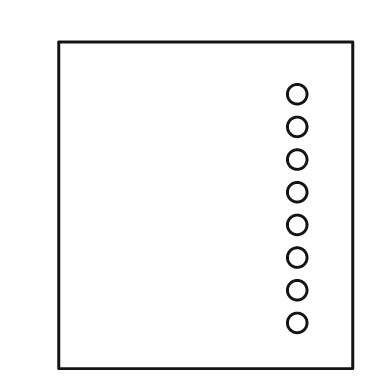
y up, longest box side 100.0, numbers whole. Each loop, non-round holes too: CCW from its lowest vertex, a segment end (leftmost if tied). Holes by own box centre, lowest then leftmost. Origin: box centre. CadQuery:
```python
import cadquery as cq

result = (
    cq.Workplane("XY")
    .moveTo(-45.0, -50.0)
    .lineTo(45.0, -50.0)
    .lineTo(45.0, 50.0)
    .lineTo(-45.0, 50.0)
    .close()
    .moveTo(28.0, -36.0)
    .circle(3.0)
    .moveTo(28.0, -26.0)
    .circle(3.0)
    .moveTo(28.0, -16.0)
    .circle(3.0)
    .moveTo(28.0, -6.0)
    .circle(3.0)
    .moveTo(28.0, 4.0)
    .circle(3.0)
    .moveTo(28.0, 14.0)
    .circle(3.0)
    .moveTo(28.0, 24.0)
    .circle(3.0)
    .moveTo(28.0, 34.0)
    .circle(3.0)
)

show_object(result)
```